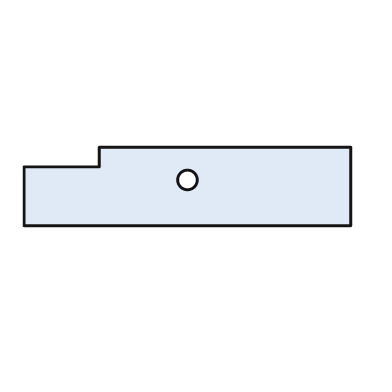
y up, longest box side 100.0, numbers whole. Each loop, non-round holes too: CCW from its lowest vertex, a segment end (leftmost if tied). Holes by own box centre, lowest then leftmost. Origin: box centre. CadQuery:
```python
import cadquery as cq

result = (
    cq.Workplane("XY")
    .moveTo(-50.0, -12.0)
    .lineTo(50.0, -12.0)
    .lineTo(50.0, 12.0)
    .lineTo(-27.0, 12.0)
    .lineTo(-27.0, 6.0)
    .lineTo(-50.0, 6.0)
    .close()
    .moveTo(0.0, 2.0)
    .circle(3.0)
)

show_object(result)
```